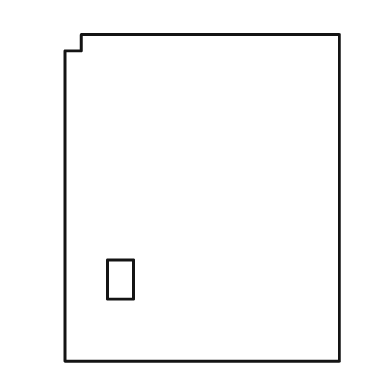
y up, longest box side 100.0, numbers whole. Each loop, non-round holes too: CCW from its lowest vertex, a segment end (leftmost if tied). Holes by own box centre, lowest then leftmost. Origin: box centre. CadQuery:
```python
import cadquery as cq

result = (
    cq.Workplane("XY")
    .moveTo(-42.0, -50.0)
    .lineTo(42.0, -50.0)
    .lineTo(42.0, 50.0)
    .lineTo(-37.0, 50.0)
    .lineTo(-37.0, 45.0)
    .lineTo(-42.0, 45.0)
    .close()
    .moveTo(-29.0, -31.0)
    .lineTo(-21.0, -31.0)
    .lineTo(-21.0, -19.0)
    .lineTo(-29.0, -19.0)
    .close()
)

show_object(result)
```